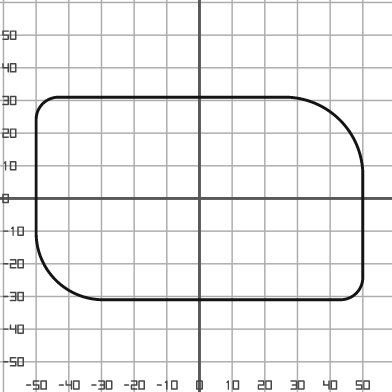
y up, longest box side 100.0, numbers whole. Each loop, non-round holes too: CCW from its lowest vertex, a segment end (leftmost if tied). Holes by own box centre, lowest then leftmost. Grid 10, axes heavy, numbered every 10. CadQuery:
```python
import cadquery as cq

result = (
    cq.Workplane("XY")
    .moveTo(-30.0, -31.0)
    .lineTo(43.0, -31.0)
    .threePointArc((48.0, -29.0), (50.0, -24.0))
    .lineTo(50.0, 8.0)
    .threePointArc((43.0, 24.0), (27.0, 31.0))
    .lineTo(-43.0, 31.0)
    .threePointArc((-48.0, 29.0), (-50.0, 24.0))
    .lineTo(-50.0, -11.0)
    .threePointArc((-44.0, -25.0), (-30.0, -31.0))
    .close()
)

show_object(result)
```